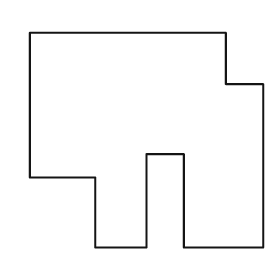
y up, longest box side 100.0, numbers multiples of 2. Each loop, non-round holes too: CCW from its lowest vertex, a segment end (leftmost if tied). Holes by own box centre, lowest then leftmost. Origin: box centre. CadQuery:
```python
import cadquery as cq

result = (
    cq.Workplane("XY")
    .moveTo(-22.0, -46.0)
    .lineTo(0.0, -46.0)
    .lineTo(0.0, -6.0)
    .lineTo(16.0, -6.0)
    .lineTo(16.0, -46.0)
    .lineTo(50.0, -46.0)
    .lineTo(50.0, 24.0)
    .lineTo(34.0, 24.0)
    .lineTo(34.0, 46.0)
    .lineTo(-50.0, 46.0)
    .lineTo(-50.0, -16.0)
    .lineTo(-22.0, -16.0)
    .close()
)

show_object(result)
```